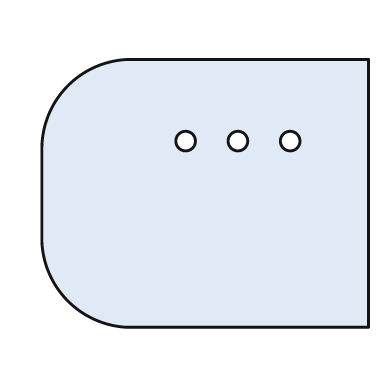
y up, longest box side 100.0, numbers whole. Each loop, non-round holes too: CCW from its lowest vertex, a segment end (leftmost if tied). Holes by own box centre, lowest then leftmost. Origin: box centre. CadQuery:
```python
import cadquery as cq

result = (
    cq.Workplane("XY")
    .moveTo(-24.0, -41.0)
    .lineTo(50.0, -41.0)
    .lineTo(50.0, 41.0)
    .lineTo(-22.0, 41.0)
    .threePointArc((-42.0, 33.0), (-50.0, 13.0))
    .lineTo(-50.0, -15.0)
    .threePointArc((-42.0, -33.0), (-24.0, -41.0))
    .close()
    .moveTo(-6.0, 16.0)
    .circle(3.0)
    .moveTo(10.0, 16.0)
    .circle(3.0)
    .moveTo(26.0, 16.0)
    .circle(3.0)
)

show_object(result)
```